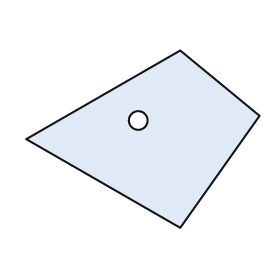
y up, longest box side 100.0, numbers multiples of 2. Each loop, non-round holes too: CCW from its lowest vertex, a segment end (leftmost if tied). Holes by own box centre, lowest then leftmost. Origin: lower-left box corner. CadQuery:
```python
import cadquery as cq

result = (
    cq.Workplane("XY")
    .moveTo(66.0, 0.0)
    .lineTo(100.0, 48.0)
    .lineTo(66.0, 76.0)
    .lineTo(0.0, 38.0)
    .close()
    .moveTo(48.0, 46.0)
    .circle(4.0)
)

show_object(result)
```